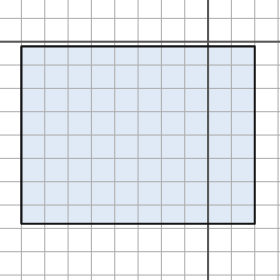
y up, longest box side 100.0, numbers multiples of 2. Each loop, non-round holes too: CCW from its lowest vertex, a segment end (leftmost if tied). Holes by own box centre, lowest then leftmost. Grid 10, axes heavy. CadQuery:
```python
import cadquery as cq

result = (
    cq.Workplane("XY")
    .moveTo(-80.0, -78.0)
    .lineTo(20.0, -78.0)
    .lineTo(20.0, -2.0)
    .lineTo(-80.0, -2.0)
    .close()
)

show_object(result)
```